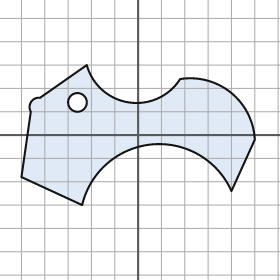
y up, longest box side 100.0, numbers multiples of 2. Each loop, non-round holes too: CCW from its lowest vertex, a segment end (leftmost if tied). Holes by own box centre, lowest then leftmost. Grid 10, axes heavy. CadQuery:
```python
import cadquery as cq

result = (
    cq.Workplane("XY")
    .moveTo(-24.0, -30.0)
    .threePointArc((6.0, -4.0), (40.0, -24.0))
    .lineTo(50.0, -2.0)
    .threePointArc((40.0, 18.0), (18.0, 24.0))
    .threePointArc((-4.0, 14.0), (-22.0, 30.0))
    .lineTo(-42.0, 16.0)
    .threePointArc((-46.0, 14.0), (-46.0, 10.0))
    .lineTo(-50.0, -18.0)
    .close()
    .moveTo(-26.0, 14.0)
    .circle(4.0)
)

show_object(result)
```